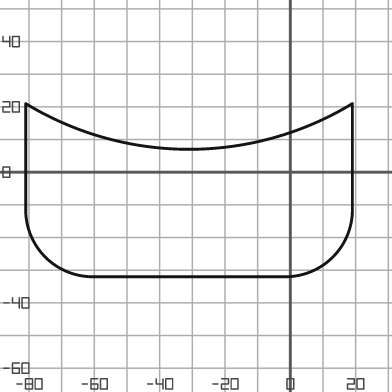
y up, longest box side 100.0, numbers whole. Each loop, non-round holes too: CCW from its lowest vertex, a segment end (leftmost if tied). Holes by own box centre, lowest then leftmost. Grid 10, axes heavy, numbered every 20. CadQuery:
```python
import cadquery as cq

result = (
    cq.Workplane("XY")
    .moveTo(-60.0, -32.0)
    .lineTo(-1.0, -32.0)
    .threePointArc((13.0, -26.0), (19.0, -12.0))
    .lineTo(19.0, 21.0)
    .threePointArc((-31.0, 7.0), (-81.0, 21.0))
    .lineTo(-81.0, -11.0)
    .threePointArc((-75.0, -26.0), (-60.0, -32.0))
    .close()
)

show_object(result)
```